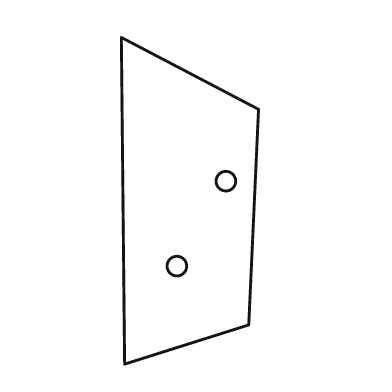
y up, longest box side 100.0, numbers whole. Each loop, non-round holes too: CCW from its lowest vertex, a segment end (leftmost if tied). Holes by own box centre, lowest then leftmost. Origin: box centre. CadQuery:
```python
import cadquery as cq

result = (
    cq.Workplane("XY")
    .moveTo(-20.0, -50.0)
    .lineTo(18.0, -38.0)
    .lineTo(21.0, 28.0)
    .lineTo(-21.0, 50.0)
    .close()
    .moveTo(-4.0, -20.0)
    .circle(3.0)
    .moveTo(11.0, 6.0)
    .circle(3.0)
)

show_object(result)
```